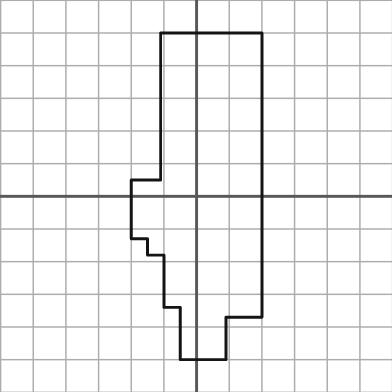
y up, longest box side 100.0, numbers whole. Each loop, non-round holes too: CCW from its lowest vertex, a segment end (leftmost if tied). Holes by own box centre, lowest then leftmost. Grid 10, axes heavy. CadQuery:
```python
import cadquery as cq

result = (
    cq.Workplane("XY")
    .moveTo(-5.0, -50.0)
    .lineTo(9.0, -50.0)
    .lineTo(9.0, -37.0)
    .lineTo(20.0, -37.0)
    .lineTo(20.0, 50.0)
    .lineTo(-11.0, 50.0)
    .lineTo(-11.0, 5.0)
    .lineTo(-20.0, 5.0)
    .lineTo(-20.0, -13.0)
    .lineTo(-15.0, -13.0)
    .lineTo(-15.0, -18.0)
    .lineTo(-10.0, -18.0)
    .lineTo(-10.0, -34.0)
    .lineTo(-5.0, -34.0)
    .close()
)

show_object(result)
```